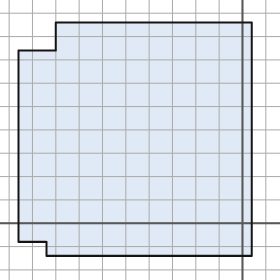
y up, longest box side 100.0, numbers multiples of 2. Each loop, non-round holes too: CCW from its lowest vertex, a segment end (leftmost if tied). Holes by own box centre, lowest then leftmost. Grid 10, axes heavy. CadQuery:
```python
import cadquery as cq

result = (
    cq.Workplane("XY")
    .moveTo(-84.0, -14.0)
    .lineTo(4.0, -14.0)
    .lineTo(4.0, 86.0)
    .lineTo(-80.0, 86.0)
    .lineTo(-80.0, 74.0)
    .lineTo(-96.0, 74.0)
    .lineTo(-96.0, -8.0)
    .lineTo(-84.0, -8.0)
    .close()
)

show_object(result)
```